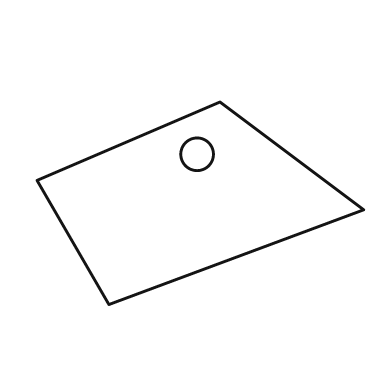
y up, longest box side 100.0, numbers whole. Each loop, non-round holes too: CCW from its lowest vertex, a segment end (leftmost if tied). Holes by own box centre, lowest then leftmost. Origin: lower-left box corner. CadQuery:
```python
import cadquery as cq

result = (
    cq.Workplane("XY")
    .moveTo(22.0, 0.0)
    .lineTo(100.0, 29.0)
    .lineTo(56.0, 62.0)
    .lineTo(0.0, 38.0)
    .close()
    .moveTo(49.0, 46.0)
    .circle(5.0)
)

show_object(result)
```